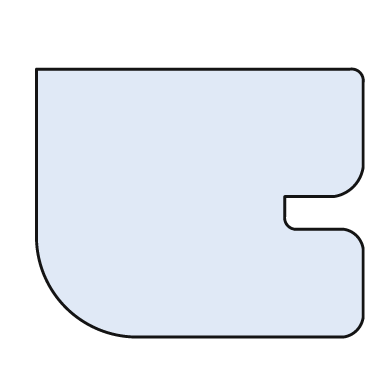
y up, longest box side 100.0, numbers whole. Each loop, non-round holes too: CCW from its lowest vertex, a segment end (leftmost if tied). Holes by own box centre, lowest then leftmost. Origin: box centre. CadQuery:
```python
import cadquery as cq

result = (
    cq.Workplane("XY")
    .moveTo(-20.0, -41.0)
    .lineTo(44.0, -41.0)
    .threePointArc((48.0, -39.0), (50.0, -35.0))
    .lineTo(50.0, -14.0)
    .threePointArc((48.0, -10.0), (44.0, -8.0))
    .lineTo(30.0, -8.0)
    .threePointArc((27.0, -7.0), (26.0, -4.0))
    .lineTo(26.0, 2.0)
    .lineTo(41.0, 2.0)
    .threePointArc((47.0, 5.0), (50.0, 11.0))
    .lineTo(50.0, 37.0)
    .threePointArc((49.0, 40.0), (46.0, 41.0))
    .lineTo(-50.0, 41.0)
    .lineTo(-50.0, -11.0)
    .threePointArc((-41.0, -32.0), (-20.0, -41.0))
    .close()
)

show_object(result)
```